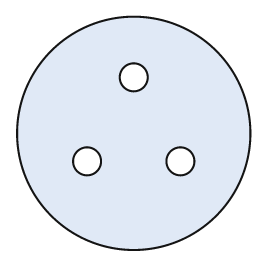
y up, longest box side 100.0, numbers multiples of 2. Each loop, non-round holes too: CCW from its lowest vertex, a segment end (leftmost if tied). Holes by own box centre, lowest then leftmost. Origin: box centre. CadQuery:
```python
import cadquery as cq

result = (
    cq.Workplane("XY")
    .moveTo(0.0, 0.0)
    .circle(50.0)
    .moveTo(-20.0, -12.0)
    .circle(6.0)
    .moveTo(20.0, -12.0)
    .circle(6.0)
    .moveTo(0.0, 24.0)
    .circle(6.0)
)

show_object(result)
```